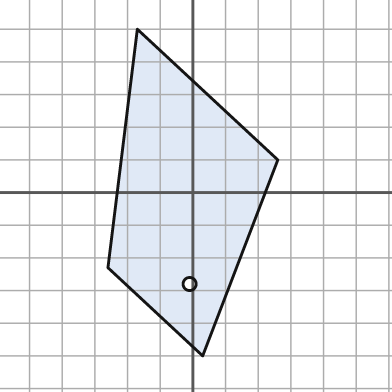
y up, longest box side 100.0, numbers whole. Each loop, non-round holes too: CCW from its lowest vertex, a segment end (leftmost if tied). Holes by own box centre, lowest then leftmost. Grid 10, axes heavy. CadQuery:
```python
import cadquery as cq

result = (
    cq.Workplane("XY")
    .moveTo(3.0, -50.0)
    .lineTo(26.0, 10.0)
    .lineTo(-17.0, 50.0)
    .lineTo(-26.0, -23.0)
    .close()
    .moveTo(-1.0, -28.0)
    .circle(2.0)
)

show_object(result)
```